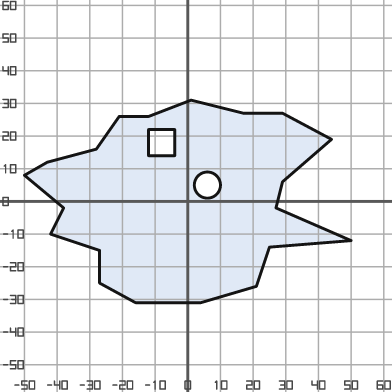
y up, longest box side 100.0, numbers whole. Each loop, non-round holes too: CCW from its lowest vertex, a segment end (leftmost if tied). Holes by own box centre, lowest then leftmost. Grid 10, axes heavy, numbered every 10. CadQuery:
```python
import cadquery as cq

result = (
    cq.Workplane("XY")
    .moveTo(-16.0, -31.0)
    .lineTo(4.0, -31.0)
    .lineTo(21.0, -26.0)
    .lineTo(25.0, -14.0)
    .lineTo(50.0, -12.0)
    .lineTo(27.0, -2.0)
    .lineTo(29.0, 6.0)
    .lineTo(44.0, 19.0)
    .lineTo(29.0, 27.0)
    .lineTo(17.0, 27.0)
    .lineTo(1.0, 31.0)
    .lineTo(-12.0, 26.0)
    .lineTo(-21.0, 26.0)
    .lineTo(-28.0, 16.0)
    .lineTo(-43.0, 12.0)
    .lineTo(-50.0, 8.0)
    .lineTo(-38.0, -2.0)
    .lineTo(-42.0, -10.0)
    .lineTo(-27.0, -15.0)
    .lineTo(-27.0, -25.0)
    .close()
    .moveTo(6.0, 5.0)
    .circle(4.0)
    .moveTo(-12.0, 14.0)
    .lineTo(-4.0, 14.0)
    .lineTo(-4.0, 22.0)
    .lineTo(-12.0, 22.0)
    .close()
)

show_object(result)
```